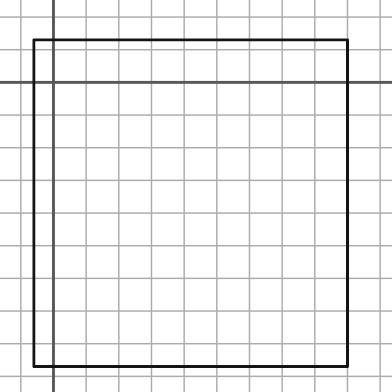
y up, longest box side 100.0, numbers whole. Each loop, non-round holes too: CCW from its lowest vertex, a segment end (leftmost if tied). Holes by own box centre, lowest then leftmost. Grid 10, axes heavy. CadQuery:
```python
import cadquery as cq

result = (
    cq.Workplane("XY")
    .moveTo(-6.0, -87.0)
    .lineTo(90.0, -87.0)
    .lineTo(90.0, 13.0)
    .lineTo(-6.0, 13.0)
    .close()
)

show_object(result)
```